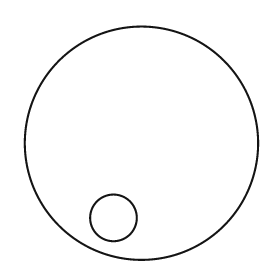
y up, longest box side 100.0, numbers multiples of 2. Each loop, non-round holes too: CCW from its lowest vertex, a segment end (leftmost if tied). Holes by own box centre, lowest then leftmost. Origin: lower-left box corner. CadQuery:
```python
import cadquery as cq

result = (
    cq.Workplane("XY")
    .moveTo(50.0, 50.0)
    .circle(50.0)
    .moveTo(38.0, 18.0)
    .circle(10.0)
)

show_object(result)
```